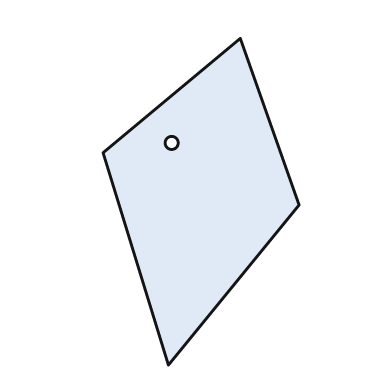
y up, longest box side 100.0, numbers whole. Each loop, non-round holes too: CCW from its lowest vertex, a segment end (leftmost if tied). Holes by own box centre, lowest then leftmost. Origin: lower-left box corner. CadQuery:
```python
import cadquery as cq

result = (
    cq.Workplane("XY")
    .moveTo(20.0, 0.0)
    .lineTo(60.0, 49.0)
    .lineTo(42.0, 100.0)
    .lineTo(0.0, 65.0)
    .close()
    .moveTo(21.0, 68.0)
    .circle(2.0)
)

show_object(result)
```